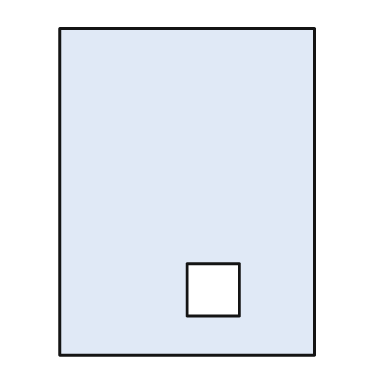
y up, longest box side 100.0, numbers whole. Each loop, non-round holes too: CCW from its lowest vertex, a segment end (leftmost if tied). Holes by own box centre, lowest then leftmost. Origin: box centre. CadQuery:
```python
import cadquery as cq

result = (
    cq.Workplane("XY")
    .moveTo(-39.0, -50.0)
    .lineTo(39.0, -50.0)
    .lineTo(39.0, 50.0)
    .lineTo(-39.0, 50.0)
    .close()
    .moveTo(0.0, -38.0)
    .lineTo(16.0, -38.0)
    .lineTo(16.0, -22.0)
    .lineTo(0.0, -22.0)
    .close()
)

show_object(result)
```